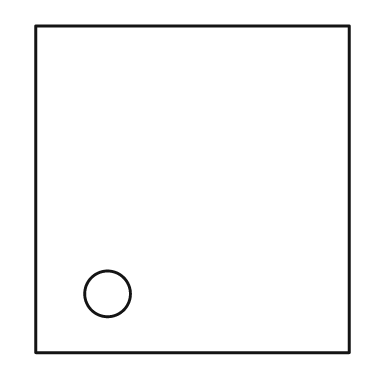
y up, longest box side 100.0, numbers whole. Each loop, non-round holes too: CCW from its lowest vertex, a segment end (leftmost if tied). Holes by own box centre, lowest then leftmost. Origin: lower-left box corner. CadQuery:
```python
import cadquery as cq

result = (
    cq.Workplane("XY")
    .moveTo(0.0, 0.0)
    .lineTo(96.0, 0.0)
    .lineTo(96.0, 100.0)
    .lineTo(0.0, 100.0)
    .close()
    .moveTo(22.0, 18.0)
    .circle(7.0)
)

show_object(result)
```